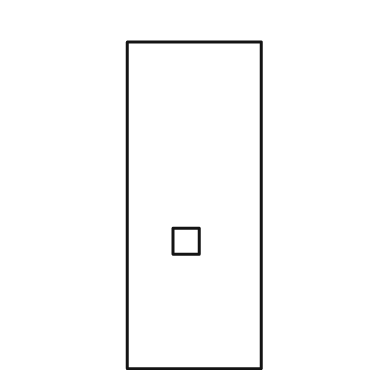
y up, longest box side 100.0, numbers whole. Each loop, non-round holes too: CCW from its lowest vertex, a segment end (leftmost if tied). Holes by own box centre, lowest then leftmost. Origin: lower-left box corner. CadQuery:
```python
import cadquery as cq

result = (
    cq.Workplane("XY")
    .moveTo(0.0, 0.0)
    .lineTo(41.0, 0.0)
    .lineTo(41.0, 100.0)
    .lineTo(0.0, 100.0)
    .close()
    .moveTo(14.0, 35.0)
    .lineTo(22.0, 35.0)
    .lineTo(22.0, 43.0)
    .lineTo(14.0, 43.0)
    .close()
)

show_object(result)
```